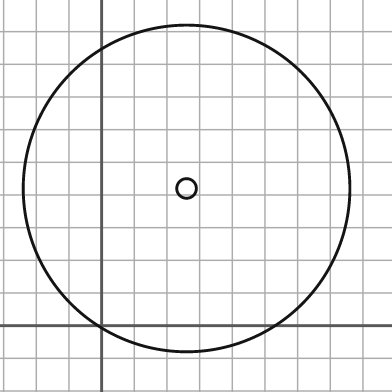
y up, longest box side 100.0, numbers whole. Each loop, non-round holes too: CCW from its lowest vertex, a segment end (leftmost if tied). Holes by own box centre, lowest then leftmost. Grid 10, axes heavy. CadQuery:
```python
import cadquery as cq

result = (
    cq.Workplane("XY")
    .moveTo(26.0, 42.0)
    .circle(50.0)
    .moveTo(26.0, 42.0)
    .circle(3.0)
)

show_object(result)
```